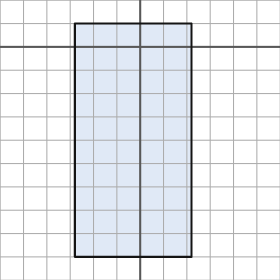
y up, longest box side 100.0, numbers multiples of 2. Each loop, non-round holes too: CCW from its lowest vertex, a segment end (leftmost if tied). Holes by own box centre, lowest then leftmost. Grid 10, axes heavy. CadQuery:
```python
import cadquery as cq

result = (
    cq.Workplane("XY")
    .moveTo(-28.0, -90.0)
    .lineTo(22.0, -90.0)
    .lineTo(22.0, 10.0)
    .lineTo(-28.0, 10.0)
    .close()
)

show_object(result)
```